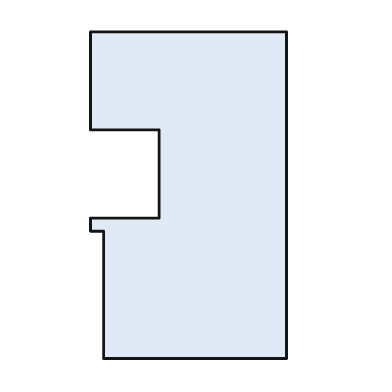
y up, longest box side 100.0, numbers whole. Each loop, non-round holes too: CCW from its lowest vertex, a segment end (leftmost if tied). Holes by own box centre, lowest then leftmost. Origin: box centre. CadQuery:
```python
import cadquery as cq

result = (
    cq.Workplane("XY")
    .moveTo(-26.0, -50.0)
    .lineTo(30.0, -50.0)
    .lineTo(30.0, 50.0)
    .lineTo(-30.0, 50.0)
    .lineTo(-30.0, 20.0)
    .lineTo(-9.0, 20.0)
    .lineTo(-9.0, -7.0)
    .lineTo(-30.0, -7.0)
    .lineTo(-30.0, -11.0)
    .lineTo(-26.0, -11.0)
    .close()
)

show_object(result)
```